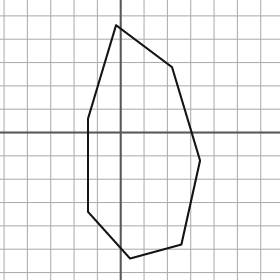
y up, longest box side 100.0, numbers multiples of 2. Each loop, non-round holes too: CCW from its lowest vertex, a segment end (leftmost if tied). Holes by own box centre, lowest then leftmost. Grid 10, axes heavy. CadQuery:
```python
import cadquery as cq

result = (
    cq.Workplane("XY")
    .moveTo(4.0, -54.0)
    .lineTo(26.0, -48.0)
    .lineTo(34.0, -12.0)
    .lineTo(22.0, 28.0)
    .lineTo(-2.0, 46.0)
    .lineTo(-14.0, 6.0)
    .lineTo(-14.0, -34.0)
    .close()
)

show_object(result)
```